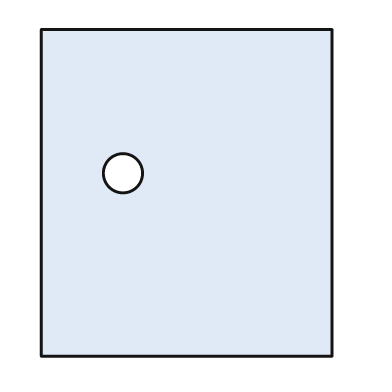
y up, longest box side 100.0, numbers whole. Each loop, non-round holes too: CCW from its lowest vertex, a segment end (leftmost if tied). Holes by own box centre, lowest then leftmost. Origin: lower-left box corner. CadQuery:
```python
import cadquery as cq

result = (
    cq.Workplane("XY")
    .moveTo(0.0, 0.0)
    .lineTo(89.0, 0.0)
    .lineTo(89.0, 100.0)
    .lineTo(0.0, 100.0)
    .close()
    .moveTo(25.0, 56.0)
    .circle(6.0)
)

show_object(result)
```